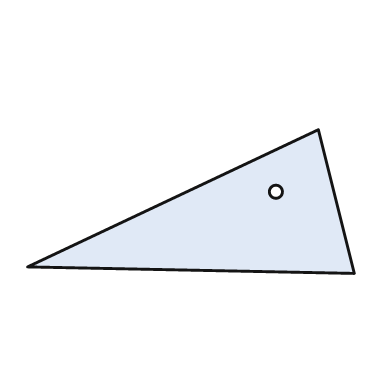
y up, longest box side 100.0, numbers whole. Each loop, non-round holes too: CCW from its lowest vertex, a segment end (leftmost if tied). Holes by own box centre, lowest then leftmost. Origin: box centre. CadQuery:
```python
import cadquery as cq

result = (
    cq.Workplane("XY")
    .moveTo(50.0, -22.0)
    .lineTo(39.0, 22.0)
    .lineTo(-50.0, -20.0)
    .close()
    .moveTo(26.0, 3.0)
    .circle(2.0)
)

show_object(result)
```